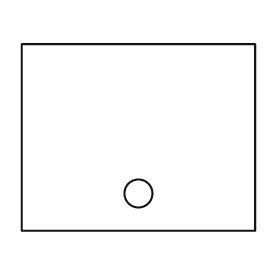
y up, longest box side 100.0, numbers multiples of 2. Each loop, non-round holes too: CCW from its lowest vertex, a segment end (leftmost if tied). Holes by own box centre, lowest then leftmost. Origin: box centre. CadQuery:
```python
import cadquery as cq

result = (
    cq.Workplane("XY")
    .moveTo(-50.0, -40.0)
    .lineTo(50.0, -40.0)
    .lineTo(50.0, 40.0)
    .lineTo(-50.0, 40.0)
    .close()
    .moveTo(0.0, -24.0)
    .circle(6.0)
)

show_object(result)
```